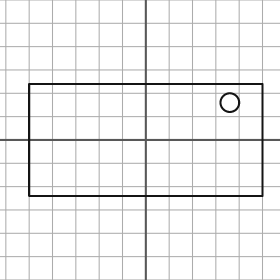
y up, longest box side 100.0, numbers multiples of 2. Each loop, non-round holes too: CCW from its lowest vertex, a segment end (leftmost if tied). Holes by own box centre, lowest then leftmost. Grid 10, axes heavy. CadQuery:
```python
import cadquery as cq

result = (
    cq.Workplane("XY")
    .moveTo(-50.0, -24.0)
    .lineTo(50.0, -24.0)
    .lineTo(50.0, 24.0)
    .lineTo(-50.0, 24.0)
    .close()
    .moveTo(36.0, 16.0)
    .circle(4.0)
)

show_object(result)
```